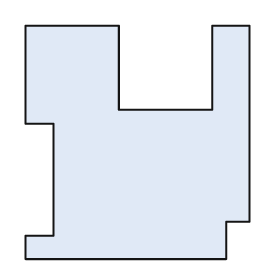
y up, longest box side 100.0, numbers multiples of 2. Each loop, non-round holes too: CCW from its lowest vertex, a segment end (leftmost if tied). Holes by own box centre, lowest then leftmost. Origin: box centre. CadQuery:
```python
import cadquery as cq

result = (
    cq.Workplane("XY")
    .moveTo(-48.0, -50.0)
    .lineTo(38.0, -50.0)
    .lineTo(38.0, -34.0)
    .lineTo(48.0, -34.0)
    .lineTo(48.0, 50.0)
    .lineTo(32.0, 50.0)
    .lineTo(32.0, 14.0)
    .lineTo(-8.0, 14.0)
    .lineTo(-8.0, 50.0)
    .lineTo(-48.0, 50.0)
    .lineTo(-48.0, 8.0)
    .lineTo(-36.0, 8.0)
    .lineTo(-36.0, -40.0)
    .lineTo(-48.0, -40.0)
    .close()
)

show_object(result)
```